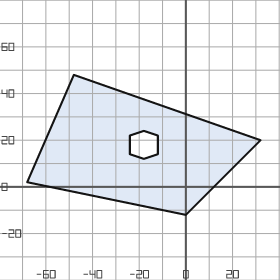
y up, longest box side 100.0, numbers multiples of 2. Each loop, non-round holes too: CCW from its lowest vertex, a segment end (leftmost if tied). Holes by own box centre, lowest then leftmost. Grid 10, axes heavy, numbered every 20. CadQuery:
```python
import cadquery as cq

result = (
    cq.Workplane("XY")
    .moveTo(0.0, -12.0)
    .lineTo(32.0, 20.0)
    .lineTo(-48.0, 48.0)
    .lineTo(-68.0, 2.0)
    .close()
    .moveTo(-18.0, 12.0)
    .lineTo(-12.0, 14.0)
    .lineTo(-12.0, 22.0)
    .lineTo(-18.0, 24.0)
    .lineTo(-24.0, 22.0)
    .lineTo(-24.0, 14.0)
    .close()
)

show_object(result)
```